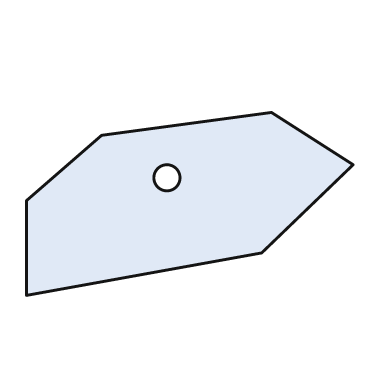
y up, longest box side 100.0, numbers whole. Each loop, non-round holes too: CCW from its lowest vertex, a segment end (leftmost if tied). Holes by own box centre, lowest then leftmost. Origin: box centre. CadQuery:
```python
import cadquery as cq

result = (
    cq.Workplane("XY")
    .moveTo(-50.0, -28.0)
    .lineTo(22.0, -15.0)
    .lineTo(50.0, 12.0)
    .lineTo(25.0, 28.0)
    .lineTo(-27.0, 21.0)
    .lineTo(-50.0, 1.0)
    .close()
    .moveTo(-7.0, 8.0)
    .circle(4.0)
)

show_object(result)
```